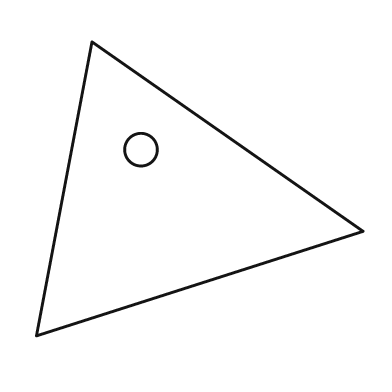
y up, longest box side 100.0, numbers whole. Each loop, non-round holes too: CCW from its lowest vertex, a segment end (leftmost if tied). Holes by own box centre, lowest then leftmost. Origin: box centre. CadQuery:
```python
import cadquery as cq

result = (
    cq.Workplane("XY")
    .moveTo(-50.0, -45.0)
    .lineTo(50.0, -13.0)
    .lineTo(-33.0, 45.0)
    .close()
    .moveTo(-18.0, 12.0)
    .circle(5.0)
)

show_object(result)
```